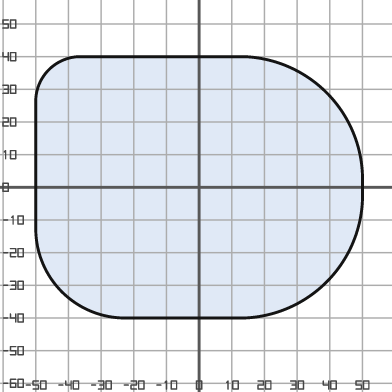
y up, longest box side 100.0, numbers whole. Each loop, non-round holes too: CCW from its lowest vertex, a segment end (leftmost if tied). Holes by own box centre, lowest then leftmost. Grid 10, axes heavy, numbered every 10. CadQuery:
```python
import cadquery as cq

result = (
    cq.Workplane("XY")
    .moveTo(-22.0, -40.0)
    .lineTo(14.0, -40.0)
    .threePointArc((39.0, -29.0), (50.0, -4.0))
    .lineTo(50.0, 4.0)
    .threePointArc((39.0, 29.0), (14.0, 40.0))
    .lineTo(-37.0, 40.0)
    .threePointArc((-46.0, 36.0), (-50.0, 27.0))
    .lineTo(-50.0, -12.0)
    .threePointArc((-42.0, -32.0), (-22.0, -40.0))
    .close()
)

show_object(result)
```